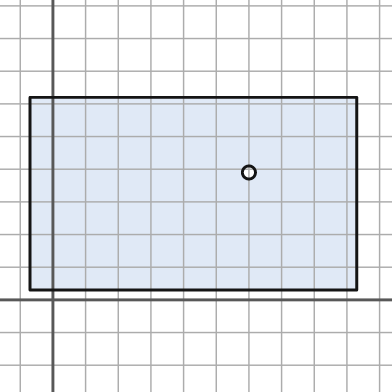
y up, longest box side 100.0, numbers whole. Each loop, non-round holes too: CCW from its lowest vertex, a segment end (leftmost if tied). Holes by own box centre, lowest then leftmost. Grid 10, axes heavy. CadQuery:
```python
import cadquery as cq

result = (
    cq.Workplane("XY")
    .moveTo(-7.0, 3.0)
    .lineTo(93.0, 3.0)
    .lineTo(93.0, 62.0)
    .lineTo(-7.0, 62.0)
    .close()
    .moveTo(60.0, 39.0)
    .circle(2.0)
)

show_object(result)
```